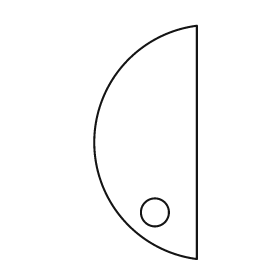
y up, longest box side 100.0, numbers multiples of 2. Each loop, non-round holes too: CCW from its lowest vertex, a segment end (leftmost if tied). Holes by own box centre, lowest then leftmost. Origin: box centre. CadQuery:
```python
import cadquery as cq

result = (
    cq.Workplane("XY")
    .moveTo(22.0, -50.0)
    .lineTo(22.0, 50.0)
    .threePointArc((-22.0, 0.0), (22.0, -50.0))
    .close()
    .moveTo(4.0, -30.0)
    .circle(6.0)
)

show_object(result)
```